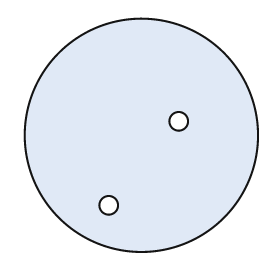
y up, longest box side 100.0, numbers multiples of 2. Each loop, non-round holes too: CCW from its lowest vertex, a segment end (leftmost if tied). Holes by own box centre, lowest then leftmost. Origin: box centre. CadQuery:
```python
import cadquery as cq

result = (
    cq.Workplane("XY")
    .moveTo(0.0, 0.0)
    .circle(50.0)
    .moveTo(-14.0, -30.0)
    .circle(4.0)
    .moveTo(16.0, 6.0)
    .circle(4.0)
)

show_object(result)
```